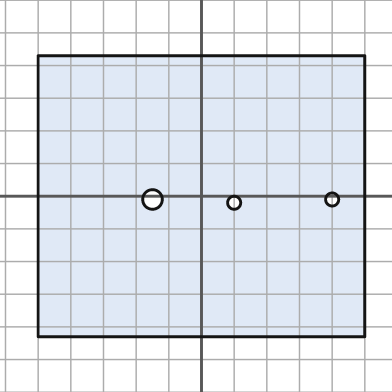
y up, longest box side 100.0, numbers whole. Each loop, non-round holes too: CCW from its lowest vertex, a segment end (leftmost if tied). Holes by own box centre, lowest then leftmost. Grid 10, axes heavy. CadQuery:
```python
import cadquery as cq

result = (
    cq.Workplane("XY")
    .moveTo(-50.0, -43.0)
    .lineTo(50.0, -43.0)
    .lineTo(50.0, 43.0)
    .lineTo(-50.0, 43.0)
    .close()
    .moveTo(10.0, -2.0)
    .circle(2.0)
    .moveTo(-15.0, -1.0)
    .circle(3.0)
    .moveTo(40.0, -1.0)
    .circle(2.0)
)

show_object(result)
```